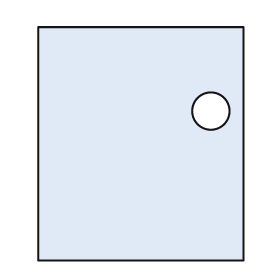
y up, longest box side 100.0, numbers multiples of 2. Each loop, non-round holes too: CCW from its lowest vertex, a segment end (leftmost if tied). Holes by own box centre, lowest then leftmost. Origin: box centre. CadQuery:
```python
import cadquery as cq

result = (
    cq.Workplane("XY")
    .moveTo(-44.0, -50.0)
    .lineTo(44.0, -50.0)
    .lineTo(44.0, 50.0)
    .lineTo(-44.0, 50.0)
    .close()
    .moveTo(30.0, 14.0)
    .circle(8.0)
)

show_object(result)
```